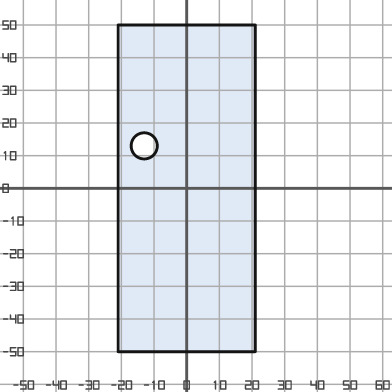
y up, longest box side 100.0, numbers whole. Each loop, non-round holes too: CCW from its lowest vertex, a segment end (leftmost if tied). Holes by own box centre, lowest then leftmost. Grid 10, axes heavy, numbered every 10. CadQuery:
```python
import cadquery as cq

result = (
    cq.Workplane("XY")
    .moveTo(-21.0, -50.0)
    .lineTo(21.0, -50.0)
    .lineTo(21.0, 50.0)
    .lineTo(-21.0, 50.0)
    .close()
    .moveTo(-13.0, 13.0)
    .circle(4.0)
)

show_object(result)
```